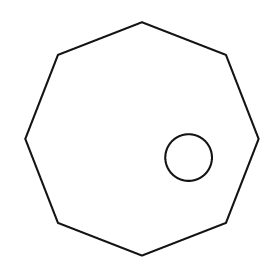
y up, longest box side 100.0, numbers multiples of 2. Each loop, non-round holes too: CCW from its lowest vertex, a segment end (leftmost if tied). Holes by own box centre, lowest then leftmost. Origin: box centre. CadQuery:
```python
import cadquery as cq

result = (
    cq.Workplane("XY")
    .moveTo(0.0, -50.0)
    .lineTo(36.0, -36.0)
    .lineTo(50.0, 0.0)
    .lineTo(36.0, 36.0)
    .lineTo(0.0, 50.0)
    .lineTo(-36.0, 36.0)
    .lineTo(-50.0, 0.0)
    .lineTo(-36.0, -36.0)
    .close()
    .moveTo(20.0, -8.0)
    .circle(10.0)
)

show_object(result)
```